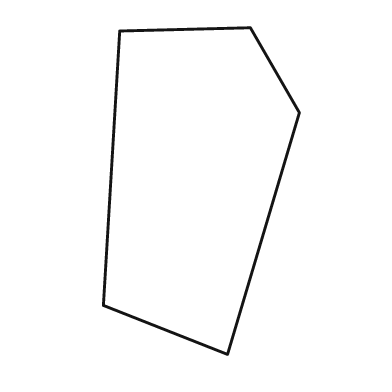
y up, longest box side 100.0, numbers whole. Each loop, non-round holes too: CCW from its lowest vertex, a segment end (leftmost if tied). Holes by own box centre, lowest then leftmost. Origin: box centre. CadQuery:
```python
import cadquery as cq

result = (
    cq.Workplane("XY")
    .moveTo(8.0, -50.0)
    .lineTo(30.0, 24.0)
    .lineTo(15.0, 50.0)
    .lineTo(-25.0, 49.0)
    .lineTo(-30.0, -35.0)
    .close()
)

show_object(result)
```